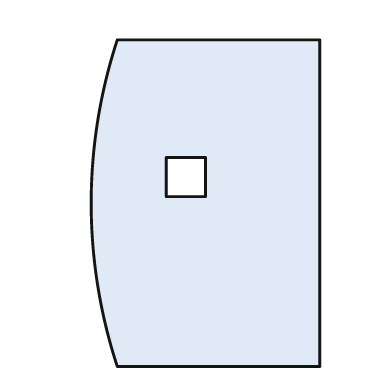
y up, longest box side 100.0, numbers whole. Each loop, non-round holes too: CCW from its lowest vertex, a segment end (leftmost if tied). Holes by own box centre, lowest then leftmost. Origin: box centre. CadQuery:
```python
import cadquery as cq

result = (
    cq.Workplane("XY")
    .moveTo(-27.0, -50.0)
    .lineTo(35.0, -50.0)
    .lineTo(35.0, 50.0)
    .lineTo(-27.0, 50.0)
    .threePointArc((-35.0, 0.0), (-27.0, -50.0))
    .close()
    .moveTo(-12.0, 2.0)
    .lineTo(0.0, 2.0)
    .lineTo(0.0, 14.0)
    .lineTo(-12.0, 14.0)
    .close()
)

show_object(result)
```